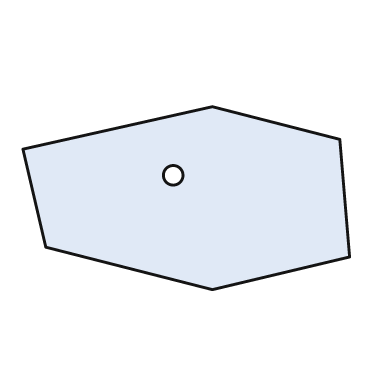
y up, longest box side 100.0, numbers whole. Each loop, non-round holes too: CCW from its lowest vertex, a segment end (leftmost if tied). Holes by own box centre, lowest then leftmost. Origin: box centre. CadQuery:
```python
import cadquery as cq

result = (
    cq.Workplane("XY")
    .moveTo(8.0, -28.0)
    .lineTo(50.0, -18.0)
    .lineTo(47.0, 18.0)
    .lineTo(8.0, 28.0)
    .lineTo(-50.0, 15.0)
    .lineTo(-43.0, -15.0)
    .close()
    .moveTo(-4.0, 7.0)
    .circle(3.0)
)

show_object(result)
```